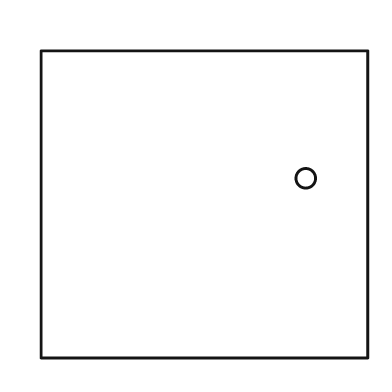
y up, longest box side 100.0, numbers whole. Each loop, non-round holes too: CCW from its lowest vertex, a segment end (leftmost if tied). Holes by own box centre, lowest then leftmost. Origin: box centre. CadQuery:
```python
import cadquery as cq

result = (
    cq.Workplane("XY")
    .moveTo(-50.0, -47.0)
    .lineTo(50.0, -47.0)
    .lineTo(50.0, 47.0)
    .lineTo(-50.0, 47.0)
    .close()
    .moveTo(31.0, 8.0)
    .circle(3.0)
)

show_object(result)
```